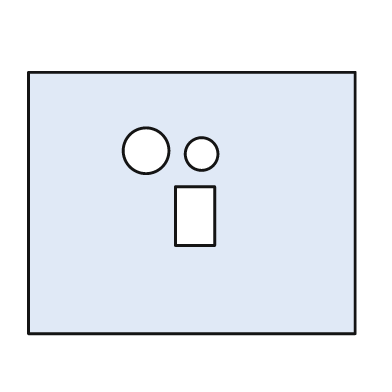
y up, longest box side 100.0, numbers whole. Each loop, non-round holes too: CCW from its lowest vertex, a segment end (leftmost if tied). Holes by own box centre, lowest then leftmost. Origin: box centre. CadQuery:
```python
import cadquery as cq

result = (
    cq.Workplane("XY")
    .moveTo(-50.0, -40.0)
    .lineTo(50.0, -40.0)
    .lineTo(50.0, 40.0)
    .lineTo(-50.0, 40.0)
    .close()
    .moveTo(-5.0, -13.0)
    .lineTo(7.0, -13.0)
    .lineTo(7.0, 5.0)
    .lineTo(-5.0, 5.0)
    .close()
    .moveTo(3.0, 15.0)
    .circle(5.0)
    .moveTo(-14.0, 16.0)
    .circle(7.0)
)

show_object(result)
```